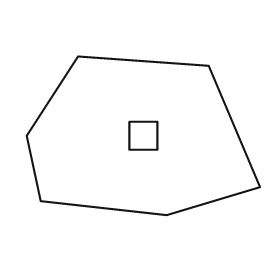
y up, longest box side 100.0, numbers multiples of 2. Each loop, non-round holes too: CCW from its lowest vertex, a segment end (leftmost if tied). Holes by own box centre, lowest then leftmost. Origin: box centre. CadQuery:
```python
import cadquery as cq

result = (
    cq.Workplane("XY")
    .moveTo(10.0, -34.0)
    .lineTo(50.0, -22.0)
    .lineTo(28.0, 30.0)
    .lineTo(-28.0, 34.0)
    .lineTo(-50.0, 0.0)
    .lineTo(-44.0, -28.0)
    .close()
    .moveTo(-6.0, -6.0)
    .lineTo(6.0, -6.0)
    .lineTo(6.0, 6.0)
    .lineTo(-6.0, 6.0)
    .close()
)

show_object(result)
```